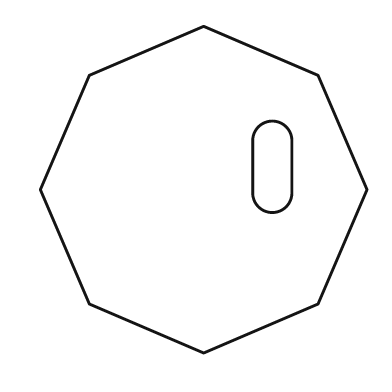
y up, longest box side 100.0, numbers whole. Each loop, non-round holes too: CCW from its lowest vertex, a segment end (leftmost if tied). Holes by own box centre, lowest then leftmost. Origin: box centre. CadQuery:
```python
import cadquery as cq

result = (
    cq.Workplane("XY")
    .moveTo(0.0, -50.0)
    .lineTo(35.0, -35.0)
    .lineTo(50.0, 0.0)
    .lineTo(35.0, 35.0)
    .lineTo(0.0, 50.0)
    .lineTo(-35.0, 35.0)
    .lineTo(-50.0, 0.0)
    .lineTo(-35.0, -35.0)
    .close()
    .moveTo(15.0, -1.0)
    .threePointArc((21.0, -7.0), (27.0, -1.0))
    .lineTo(27.0, 15.0)
    .threePointArc((21.0, 21.0), (15.0, 15.0))
    .close()
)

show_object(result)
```